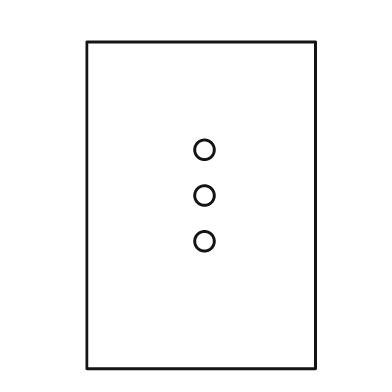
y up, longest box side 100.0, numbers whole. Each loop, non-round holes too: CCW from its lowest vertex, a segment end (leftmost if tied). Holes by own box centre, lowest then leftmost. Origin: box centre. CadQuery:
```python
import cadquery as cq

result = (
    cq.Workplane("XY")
    .moveTo(-35.0, -50.0)
    .lineTo(35.0, -50.0)
    .lineTo(35.0, 50.0)
    .lineTo(-35.0, 50.0)
    .close()
    .moveTo(1.0, -11.0)
    .circle(3.0)
    .moveTo(1.0, 3.0)
    .circle(3.0)
    .moveTo(1.0, 17.0)
    .circle(3.0)
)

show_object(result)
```